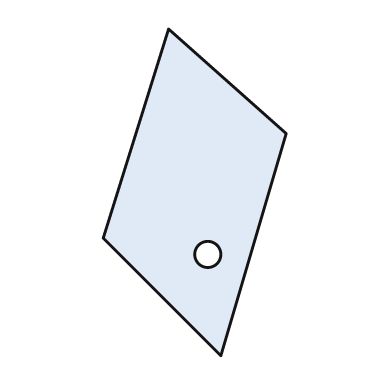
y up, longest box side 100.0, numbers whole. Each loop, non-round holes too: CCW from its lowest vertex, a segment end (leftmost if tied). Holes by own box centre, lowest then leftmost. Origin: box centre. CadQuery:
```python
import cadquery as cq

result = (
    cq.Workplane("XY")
    .moveTo(8.0, -50.0)
    .lineTo(28.0, 18.0)
    .lineTo(-8.0, 50.0)
    .lineTo(-28.0, -14.0)
    .close()
    .moveTo(4.0, -19.0)
    .circle(4.0)
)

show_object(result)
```